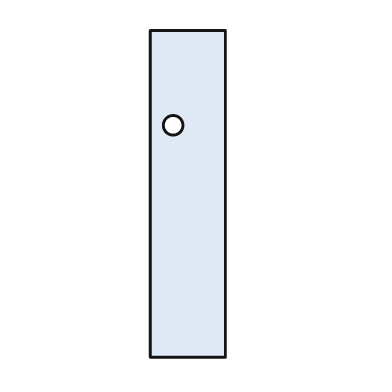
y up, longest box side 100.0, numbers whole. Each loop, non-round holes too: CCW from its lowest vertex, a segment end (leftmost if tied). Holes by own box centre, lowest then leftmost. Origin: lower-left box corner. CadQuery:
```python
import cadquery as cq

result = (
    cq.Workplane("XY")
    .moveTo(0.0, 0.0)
    .lineTo(23.0, 0.0)
    .lineTo(23.0, 100.0)
    .lineTo(0.0, 100.0)
    .close()
    .moveTo(7.0, 71.0)
    .circle(3.0)
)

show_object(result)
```